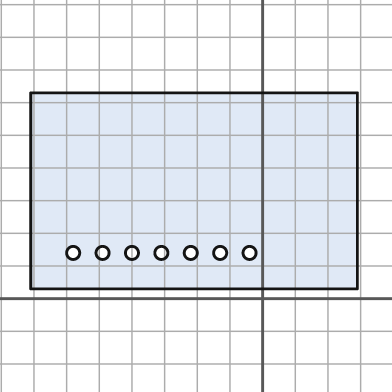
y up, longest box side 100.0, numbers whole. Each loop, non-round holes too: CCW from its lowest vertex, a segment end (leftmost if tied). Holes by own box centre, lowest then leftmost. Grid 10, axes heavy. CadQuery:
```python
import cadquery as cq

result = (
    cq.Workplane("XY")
    .moveTo(-71.0, 3.0)
    .lineTo(29.0, 3.0)
    .lineTo(29.0, 63.0)
    .lineTo(-71.0, 63.0)
    .close()
    .moveTo(-58.0, 14.0)
    .circle(2.0)
    .moveTo(-49.0, 14.0)
    .circle(2.0)
    .moveTo(-40.0, 14.0)
    .circle(2.0)
    .moveTo(-31.0, 14.0)
    .circle(2.0)
    .moveTo(-22.0, 14.0)
    .circle(2.0)
    .moveTo(-13.0, 14.0)
    .circle(2.0)
    .moveTo(-4.0, 14.0)
    .circle(2.0)
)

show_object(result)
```